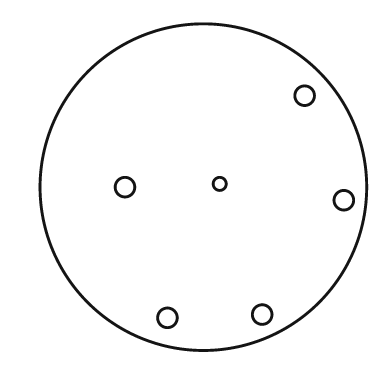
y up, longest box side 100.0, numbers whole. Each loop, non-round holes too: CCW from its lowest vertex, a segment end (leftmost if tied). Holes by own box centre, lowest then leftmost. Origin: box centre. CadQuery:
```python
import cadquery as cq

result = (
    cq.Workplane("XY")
    .moveTo(0.0, 0.0)
    .circle(50.0)
    .moveTo(-11.0, -40.0)
    .circle(3.0)
    .moveTo(18.0, -39.0)
    .circle(3.0)
    .moveTo(43.0, -4.0)
    .circle(3.0)
    .moveTo(-24.0, 0.0)
    .circle(3.0)
    .moveTo(5.0, 1.0)
    .circle(2.0)
    .moveTo(31.0, 28.0)
    .circle(3.0)
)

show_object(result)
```